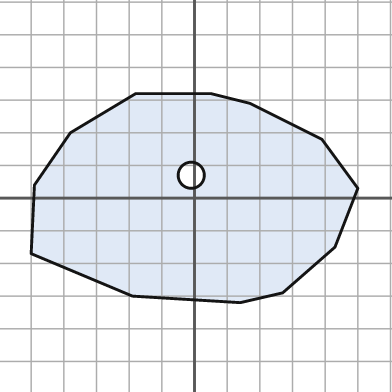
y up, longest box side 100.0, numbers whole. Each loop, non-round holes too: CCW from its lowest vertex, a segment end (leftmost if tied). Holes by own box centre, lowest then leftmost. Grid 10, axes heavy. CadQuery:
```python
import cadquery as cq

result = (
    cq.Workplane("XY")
    .moveTo(14.0, -32.0)
    .lineTo(27.0, -29.0)
    .lineTo(43.0, -15.0)
    .lineTo(50.0, 3.0)
    .lineTo(39.0, 18.0)
    .lineTo(17.0, 29.0)
    .lineTo(5.0, 32.0)
    .lineTo(-18.0, 32.0)
    .lineTo(-38.0, 20.0)
    .lineTo(-49.0, 4.0)
    .lineTo(-50.0, -17.0)
    .lineTo(-19.0, -30.0)
    .close()
    .moveTo(-1.0, 7.0)
    .circle(4.0)
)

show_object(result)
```